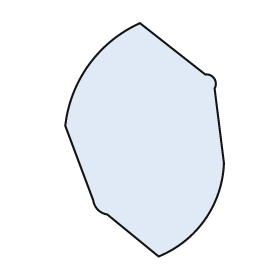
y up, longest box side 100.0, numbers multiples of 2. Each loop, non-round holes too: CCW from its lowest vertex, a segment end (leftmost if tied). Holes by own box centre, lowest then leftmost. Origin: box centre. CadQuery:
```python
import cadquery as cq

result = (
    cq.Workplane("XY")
    .moveTo(6.0, -50.0)
    .threePointArc((26.0, -34.0), (34.0, -10.0))
    .lineTo(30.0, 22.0)
    .threePointArc((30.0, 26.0), (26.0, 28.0))
    .lineTo(-2.0, 50.0)
    .threePointArc((-24.0, 32.0), (-34.0, 6.0))
    .lineTo(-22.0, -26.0)
    .threePointArc((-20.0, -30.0), (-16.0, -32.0))
    .close()
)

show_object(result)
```